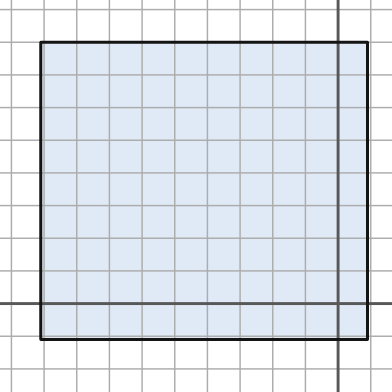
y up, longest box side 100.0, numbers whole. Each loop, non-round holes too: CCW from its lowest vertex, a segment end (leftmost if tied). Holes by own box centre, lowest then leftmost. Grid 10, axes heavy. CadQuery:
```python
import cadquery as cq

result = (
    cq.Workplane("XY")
    .moveTo(-91.0, -11.0)
    .lineTo(9.0, -11.0)
    .lineTo(9.0, 80.0)
    .lineTo(-91.0, 80.0)
    .close()
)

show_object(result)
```